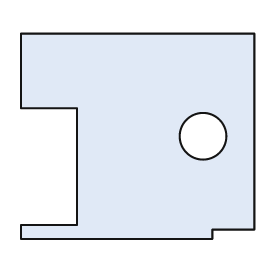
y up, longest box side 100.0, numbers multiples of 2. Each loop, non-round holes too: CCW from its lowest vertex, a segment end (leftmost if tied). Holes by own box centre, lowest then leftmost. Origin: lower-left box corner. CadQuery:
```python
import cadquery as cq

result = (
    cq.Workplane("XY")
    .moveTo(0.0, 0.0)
    .lineTo(82.0, 0.0)
    .lineTo(82.0, 4.0)
    .lineTo(100.0, 4.0)
    .lineTo(100.0, 88.0)
    .lineTo(0.0, 88.0)
    .lineTo(0.0, 56.0)
    .lineTo(24.0, 56.0)
    .lineTo(24.0, 6.0)
    .lineTo(0.0, 6.0)
    .close()
    .moveTo(78.0, 44.0)
    .circle(10.0)
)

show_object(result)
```